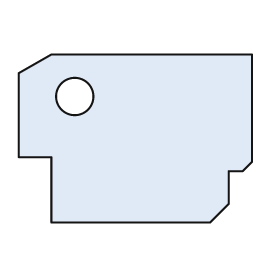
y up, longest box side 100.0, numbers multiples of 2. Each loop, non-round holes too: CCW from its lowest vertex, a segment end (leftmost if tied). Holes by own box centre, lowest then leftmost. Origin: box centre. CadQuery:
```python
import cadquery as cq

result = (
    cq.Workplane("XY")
    .moveTo(-36.0, -36.0)
    .lineTo(32.0, -36.0)
    .lineTo(40.0, -28.0)
    .lineTo(40.0, -14.0)
    .lineTo(46.0, -14.0)
    .lineTo(50.0, -10.0)
    .lineTo(50.0, 36.0)
    .lineTo(-36.0, 36.0)
    .lineTo(-50.0, 28.0)
    .lineTo(-50.0, -8.0)
    .lineTo(-36.0, -8.0)
    .close()
    .moveTo(-26.0, 18.0)
    .circle(8.0)
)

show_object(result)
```